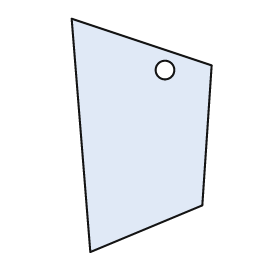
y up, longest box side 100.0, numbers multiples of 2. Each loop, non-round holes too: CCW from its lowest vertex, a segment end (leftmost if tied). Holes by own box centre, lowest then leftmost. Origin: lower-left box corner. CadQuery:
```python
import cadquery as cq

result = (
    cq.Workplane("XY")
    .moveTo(8.0, 0.0)
    .lineTo(56.0, 20.0)
    .lineTo(60.0, 80.0)
    .lineTo(0.0, 100.0)
    .close()
    .moveTo(40.0, 78.0)
    .circle(4.0)
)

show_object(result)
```